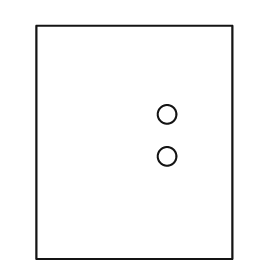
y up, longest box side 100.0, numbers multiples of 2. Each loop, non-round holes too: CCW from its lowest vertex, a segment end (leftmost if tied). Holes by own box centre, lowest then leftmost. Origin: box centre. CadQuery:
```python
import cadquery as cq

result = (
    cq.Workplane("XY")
    .moveTo(-42.0, -50.0)
    .lineTo(42.0, -50.0)
    .lineTo(42.0, 50.0)
    .lineTo(-42.0, 50.0)
    .close()
    .moveTo(14.0, -6.0)
    .circle(4.0)
    .moveTo(14.0, 12.0)
    .circle(4.0)
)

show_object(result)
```